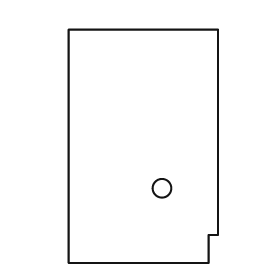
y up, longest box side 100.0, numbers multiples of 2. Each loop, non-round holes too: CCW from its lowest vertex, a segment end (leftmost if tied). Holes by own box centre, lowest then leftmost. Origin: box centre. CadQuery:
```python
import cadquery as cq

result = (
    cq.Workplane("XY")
    .moveTo(-32.0, -50.0)
    .lineTo(28.0, -50.0)
    .lineTo(28.0, -38.0)
    .lineTo(32.0, -38.0)
    .lineTo(32.0, 50.0)
    .lineTo(-32.0, 50.0)
    .close()
    .moveTo(8.0, -18.0)
    .circle(4.0)
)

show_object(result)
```